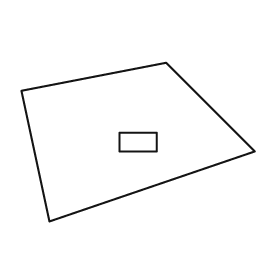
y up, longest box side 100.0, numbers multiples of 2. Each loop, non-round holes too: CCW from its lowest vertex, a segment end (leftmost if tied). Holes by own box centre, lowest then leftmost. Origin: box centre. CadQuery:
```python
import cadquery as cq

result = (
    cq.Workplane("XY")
    .moveTo(-38.0, -34.0)
    .lineTo(50.0, -4.0)
    .lineTo(12.0, 34.0)
    .lineTo(-50.0, 22.0)
    .close()
    .moveTo(-8.0, -4.0)
    .lineTo(8.0, -4.0)
    .lineTo(8.0, 4.0)
    .lineTo(-8.0, 4.0)
    .close()
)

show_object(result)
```